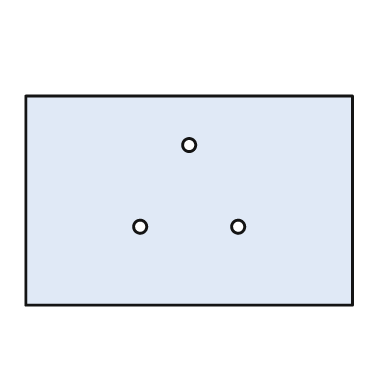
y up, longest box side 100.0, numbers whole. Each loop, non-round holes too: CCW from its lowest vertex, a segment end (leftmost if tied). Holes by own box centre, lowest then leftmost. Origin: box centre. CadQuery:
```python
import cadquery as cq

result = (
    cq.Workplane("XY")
    .moveTo(-50.0, -32.0)
    .lineTo(50.0, -32.0)
    .lineTo(50.0, 32.0)
    .lineTo(-50.0, 32.0)
    .close()
    .moveTo(-15.0, -8.0)
    .circle(2.0)
    .moveTo(15.0, -8.0)
    .circle(2.0)
    .moveTo(0.0, 17.0)
    .circle(2.0)
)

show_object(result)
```